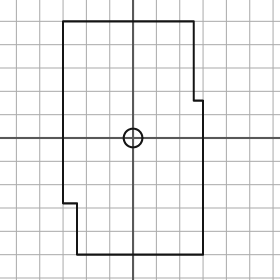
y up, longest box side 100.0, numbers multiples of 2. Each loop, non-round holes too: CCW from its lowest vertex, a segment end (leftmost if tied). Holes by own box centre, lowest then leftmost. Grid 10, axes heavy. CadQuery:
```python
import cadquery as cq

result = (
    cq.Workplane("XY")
    .moveTo(-24.0, -50.0)
    .lineTo(30.0, -50.0)
    .lineTo(30.0, 16.0)
    .lineTo(26.0, 16.0)
    .lineTo(26.0, 50.0)
    .lineTo(-30.0, 50.0)
    .lineTo(-30.0, -28.0)
    .lineTo(-24.0, -28.0)
    .close()
    .moveTo(0.0, 0.0)
    .circle(4.0)
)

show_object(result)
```